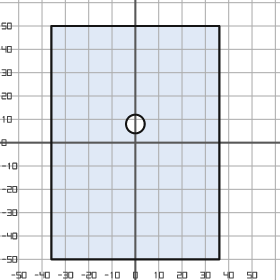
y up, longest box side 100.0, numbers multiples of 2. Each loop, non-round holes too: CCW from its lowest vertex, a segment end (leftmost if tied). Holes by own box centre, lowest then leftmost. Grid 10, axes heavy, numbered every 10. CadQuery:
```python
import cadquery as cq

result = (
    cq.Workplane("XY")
    .moveTo(-36.0, -50.0)
    .lineTo(36.0, -50.0)
    .lineTo(36.0, 50.0)
    .lineTo(-36.0, 50.0)
    .close()
    .moveTo(0.0, 8.0)
    .circle(4.0)
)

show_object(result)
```